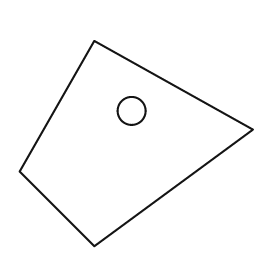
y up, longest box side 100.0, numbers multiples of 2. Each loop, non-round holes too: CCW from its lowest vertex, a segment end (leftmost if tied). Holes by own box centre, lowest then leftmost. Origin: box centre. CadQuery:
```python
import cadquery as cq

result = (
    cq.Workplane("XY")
    .moveTo(-18.0, -44.0)
    .lineTo(50.0, 6.0)
    .lineTo(-18.0, 44.0)
    .lineTo(-50.0, -12.0)
    .close()
    .moveTo(-2.0, 14.0)
    .circle(6.0)
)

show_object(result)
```